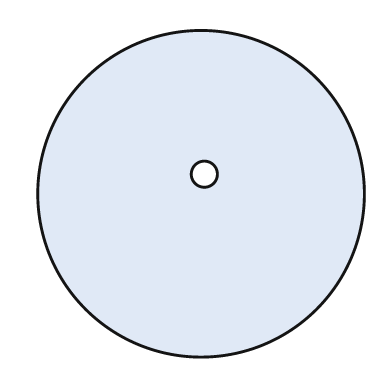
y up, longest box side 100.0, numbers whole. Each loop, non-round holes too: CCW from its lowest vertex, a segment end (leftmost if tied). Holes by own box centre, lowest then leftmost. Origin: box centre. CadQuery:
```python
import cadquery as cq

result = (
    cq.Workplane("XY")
    .moveTo(0.0, 0.0)
    .circle(50.0)
    .moveTo(1.0, 6.0)
    .circle(4.0)
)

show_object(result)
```